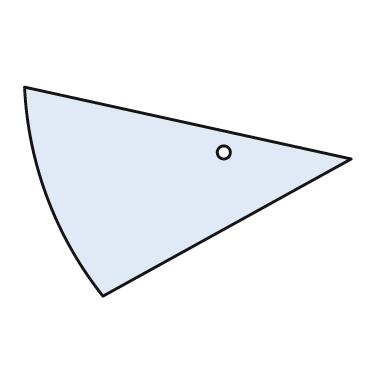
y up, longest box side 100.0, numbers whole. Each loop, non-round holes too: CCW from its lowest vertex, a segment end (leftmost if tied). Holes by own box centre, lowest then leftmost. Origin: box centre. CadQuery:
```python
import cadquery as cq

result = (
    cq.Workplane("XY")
    .moveTo(-26.0, -32.0)
    .lineTo(50.0, 10.0)
    .lineTo(-50.0, 32.0)
    .threePointArc((-43.0, -2.0), (-26.0, -32.0))
    .close()
    .moveTo(11.0, 12.0)
    .circle(2.0)
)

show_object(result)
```